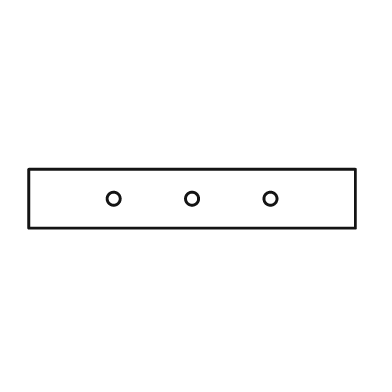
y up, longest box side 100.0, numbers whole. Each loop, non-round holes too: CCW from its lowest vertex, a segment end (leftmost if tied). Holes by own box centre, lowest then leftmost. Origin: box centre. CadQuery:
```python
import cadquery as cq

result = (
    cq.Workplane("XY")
    .moveTo(-50.0, -9.0)
    .lineTo(50.0, -9.0)
    .lineTo(50.0, 9.0)
    .lineTo(-50.0, 9.0)
    .close()
    .moveTo(-24.0, 0.0)
    .circle(2.0)
    .moveTo(0.0, 0.0)
    .circle(2.0)
    .moveTo(24.0, 0.0)
    .circle(2.0)
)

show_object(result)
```